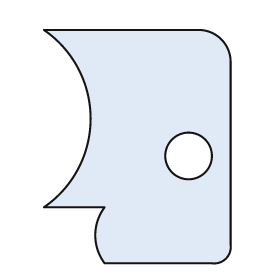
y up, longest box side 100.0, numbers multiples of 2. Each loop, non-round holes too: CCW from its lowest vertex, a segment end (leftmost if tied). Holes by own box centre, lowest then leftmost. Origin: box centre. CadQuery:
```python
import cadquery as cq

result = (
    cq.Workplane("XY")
    .moveTo(-14.0, -50.0)
    .lineTo(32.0, -50.0)
    .threePointArc((38.0, -48.0), (40.0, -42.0))
    .lineTo(40.0, 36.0)
    .threePointArc((36.0, 46.0), (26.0, 50.0))
    .lineTo(-40.0, 50.0)
    .threePointArc((-20.0, 12.0), (-40.0, -26.0))
    .lineTo(-14.0, -26.0)
    .threePointArc((-18.0, -38.0), (-14.0, -50.0))
    .close()
    .moveTo(22.0, -4.0)
    .circle(10.0)
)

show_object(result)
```